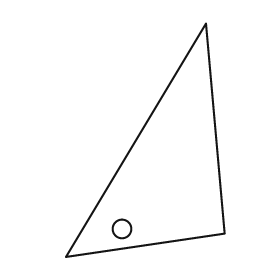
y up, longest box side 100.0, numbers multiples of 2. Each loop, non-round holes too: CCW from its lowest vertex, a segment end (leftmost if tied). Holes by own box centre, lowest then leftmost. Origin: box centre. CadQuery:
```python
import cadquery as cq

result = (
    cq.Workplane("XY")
    .moveTo(-34.0, -50.0)
    .lineTo(34.0, -40.0)
    .lineTo(26.0, 50.0)
    .close()
    .moveTo(-10.0, -38.0)
    .circle(4.0)
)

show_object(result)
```